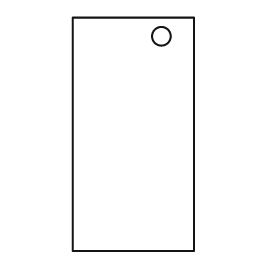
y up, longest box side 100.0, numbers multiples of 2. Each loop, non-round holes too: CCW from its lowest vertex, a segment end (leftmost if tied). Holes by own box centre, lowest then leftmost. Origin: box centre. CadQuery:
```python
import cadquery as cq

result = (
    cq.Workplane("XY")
    .moveTo(-26.0, -50.0)
    .lineTo(26.0, -50.0)
    .lineTo(26.0, 50.0)
    .lineTo(-26.0, 50.0)
    .close()
    .moveTo(12.0, 42.0)
    .circle(4.0)
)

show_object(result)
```